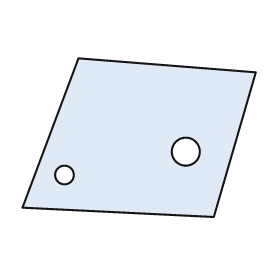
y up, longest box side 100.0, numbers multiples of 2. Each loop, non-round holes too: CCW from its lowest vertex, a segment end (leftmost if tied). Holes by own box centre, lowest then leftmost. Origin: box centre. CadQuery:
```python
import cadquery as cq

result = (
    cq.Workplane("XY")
    .moveTo(32.0, -34.0)
    .lineTo(50.0, 28.0)
    .lineTo(-26.0, 34.0)
    .lineTo(-50.0, -30.0)
    .close()
    .moveTo(-32.0, -16.0)
    .circle(4.0)
    .moveTo(20.0, -6.0)
    .circle(6.0)
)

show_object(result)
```